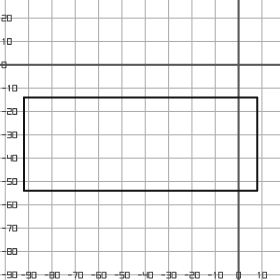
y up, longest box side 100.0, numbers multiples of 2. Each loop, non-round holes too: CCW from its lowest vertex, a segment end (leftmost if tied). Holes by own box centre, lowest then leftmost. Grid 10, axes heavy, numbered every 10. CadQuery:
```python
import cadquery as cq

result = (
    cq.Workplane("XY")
    .moveTo(-92.0, -54.0)
    .lineTo(8.0, -54.0)
    .lineTo(8.0, -14.0)
    .lineTo(-92.0, -14.0)
    .close()
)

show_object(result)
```